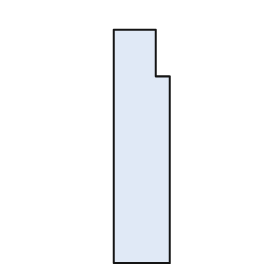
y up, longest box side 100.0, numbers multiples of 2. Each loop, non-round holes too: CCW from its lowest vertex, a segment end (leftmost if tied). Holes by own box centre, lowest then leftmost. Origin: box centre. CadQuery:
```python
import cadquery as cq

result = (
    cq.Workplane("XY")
    .moveTo(-12.0, -50.0)
    .lineTo(12.0, -50.0)
    .lineTo(12.0, 30.0)
    .lineTo(6.0, 30.0)
    .lineTo(6.0, 50.0)
    .lineTo(-12.0, 50.0)
    .close()
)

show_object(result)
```